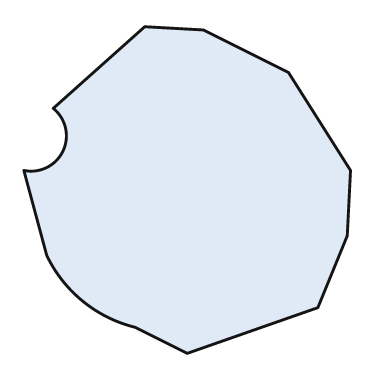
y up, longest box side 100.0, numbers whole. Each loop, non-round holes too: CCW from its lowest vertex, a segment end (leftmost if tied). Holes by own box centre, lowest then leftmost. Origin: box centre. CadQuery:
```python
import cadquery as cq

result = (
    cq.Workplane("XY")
    .moveTo(0.0, -50.0)
    .lineTo(40.0, -36.0)
    .lineTo(49.0, -14.0)
    .lineTo(50.0, 6.0)
    .lineTo(31.0, 36.0)
    .lineTo(5.0, 49.0)
    .lineTo(-13.0, 50.0)
    .lineTo(-41.0, 25.0)
    .threePointArc((-38.0, 12.0), (-50.0, 6.0))
    .lineTo(-43.0, -20.0)
    .threePointArc((-32.0, -34.0), (-16.0, -42.0))
    .close()
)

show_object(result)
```